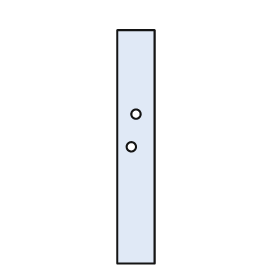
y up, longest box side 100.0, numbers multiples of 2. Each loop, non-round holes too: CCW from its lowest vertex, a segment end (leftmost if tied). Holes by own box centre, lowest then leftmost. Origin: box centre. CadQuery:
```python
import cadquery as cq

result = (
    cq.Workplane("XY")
    .moveTo(-8.0, -50.0)
    .lineTo(8.0, -50.0)
    .lineTo(8.0, 50.0)
    .lineTo(-8.0, 50.0)
    .close()
    .moveTo(-2.0, 0.0)
    .circle(2.0)
    .moveTo(0.0, 14.0)
    .circle(2.0)
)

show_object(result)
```